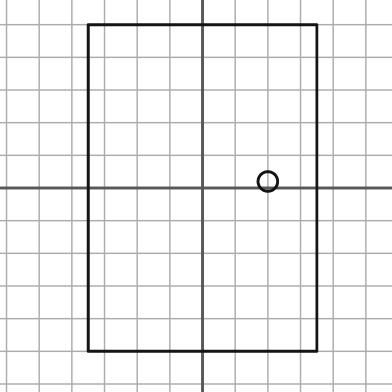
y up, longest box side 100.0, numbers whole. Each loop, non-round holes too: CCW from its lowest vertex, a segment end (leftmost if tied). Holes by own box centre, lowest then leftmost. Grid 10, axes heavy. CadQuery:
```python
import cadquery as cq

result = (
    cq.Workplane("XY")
    .moveTo(-35.0, -50.0)
    .lineTo(35.0, -50.0)
    .lineTo(35.0, 50.0)
    .lineTo(-35.0, 50.0)
    .close()
    .moveTo(20.0, 2.0)
    .circle(3.0)
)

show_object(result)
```